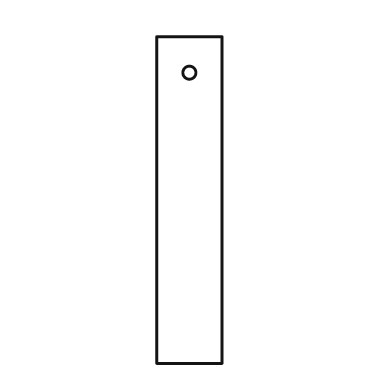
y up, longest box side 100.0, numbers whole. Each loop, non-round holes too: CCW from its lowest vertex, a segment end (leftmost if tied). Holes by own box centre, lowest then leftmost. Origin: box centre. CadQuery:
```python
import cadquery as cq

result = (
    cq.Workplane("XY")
    .moveTo(-10.0, -50.0)
    .lineTo(10.0, -50.0)
    .lineTo(10.0, 50.0)
    .lineTo(-10.0, 50.0)
    .close()
    .moveTo(0.0, 39.0)
    .circle(2.0)
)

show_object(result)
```